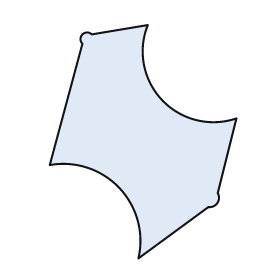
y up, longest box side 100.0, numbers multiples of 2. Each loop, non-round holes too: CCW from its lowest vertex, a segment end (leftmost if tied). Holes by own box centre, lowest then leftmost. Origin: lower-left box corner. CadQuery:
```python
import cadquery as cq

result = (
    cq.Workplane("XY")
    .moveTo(38.0, 0.0)
    .lineTo(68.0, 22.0)
    .threePointArc((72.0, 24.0), (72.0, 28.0))
    .lineTo(80.0, 60.0)
    .threePointArc((48.0, 68.0), (42.0, 100.0))
    .lineTo(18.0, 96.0)
    .threePointArc((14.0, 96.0), (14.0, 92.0))
    .lineTo(0.0, 40.0)
    .threePointArc((30.0, 30.0), (38.0, 0.0))
    .close()
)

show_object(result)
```